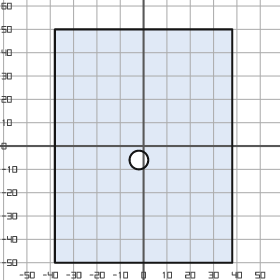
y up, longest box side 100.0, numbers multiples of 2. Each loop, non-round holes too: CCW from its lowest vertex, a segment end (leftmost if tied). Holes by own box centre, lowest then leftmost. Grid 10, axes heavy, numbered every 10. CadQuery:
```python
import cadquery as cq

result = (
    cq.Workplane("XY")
    .moveTo(-38.0, -50.0)
    .lineTo(38.0, -50.0)
    .lineTo(38.0, 50.0)
    .lineTo(-38.0, 50.0)
    .close()
    .moveTo(-2.0, -6.0)
    .circle(4.0)
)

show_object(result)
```